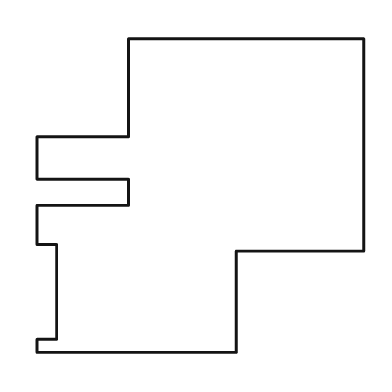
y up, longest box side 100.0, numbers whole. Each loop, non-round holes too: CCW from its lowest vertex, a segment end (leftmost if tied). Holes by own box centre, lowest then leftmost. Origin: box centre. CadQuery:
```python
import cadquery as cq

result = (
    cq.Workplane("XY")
    .moveTo(-50.0, -48.0)
    .lineTo(11.0, -48.0)
    .lineTo(11.0, -17.0)
    .lineTo(50.0, -17.0)
    .lineTo(50.0, 48.0)
    .lineTo(-22.0, 48.0)
    .lineTo(-22.0, 18.0)
    .lineTo(-50.0, 18.0)
    .lineTo(-50.0, 5.0)
    .lineTo(-22.0, 5.0)
    .lineTo(-22.0, -3.0)
    .lineTo(-50.0, -3.0)
    .lineTo(-50.0, -15.0)
    .lineTo(-44.0, -15.0)
    .lineTo(-44.0, -44.0)
    .lineTo(-50.0, -44.0)
    .close()
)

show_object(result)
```